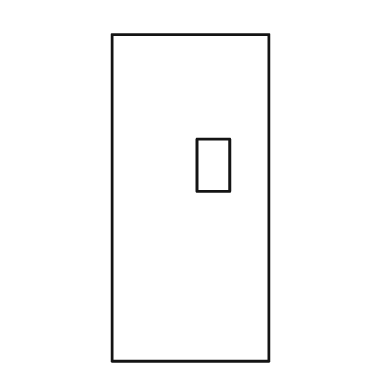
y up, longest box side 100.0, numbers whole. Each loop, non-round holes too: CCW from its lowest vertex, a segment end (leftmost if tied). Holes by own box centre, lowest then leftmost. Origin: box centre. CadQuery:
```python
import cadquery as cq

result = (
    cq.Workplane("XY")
    .moveTo(-24.0, -50.0)
    .lineTo(24.0, -50.0)
    .lineTo(24.0, 50.0)
    .lineTo(-24.0, 50.0)
    .close()
    .moveTo(2.0, 2.0)
    .lineTo(12.0, 2.0)
    .lineTo(12.0, 18.0)
    .lineTo(2.0, 18.0)
    .close()
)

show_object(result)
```